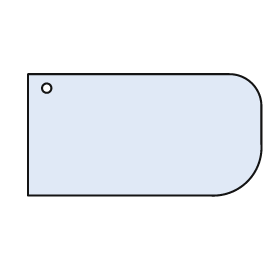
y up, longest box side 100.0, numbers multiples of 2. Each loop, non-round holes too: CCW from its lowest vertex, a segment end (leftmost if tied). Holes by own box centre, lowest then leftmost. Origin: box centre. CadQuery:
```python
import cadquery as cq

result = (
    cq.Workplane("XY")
    .moveTo(-50.0, -26.0)
    .lineTo(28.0, -26.0)
    .threePointArc((44.0, -20.0), (50.0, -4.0))
    .lineTo(50.0, 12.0)
    .threePointArc((46.0, 22.0), (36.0, 26.0))
    .lineTo(-50.0, 26.0)
    .close()
    .moveTo(-42.0, 20.0)
    .circle(2.0)
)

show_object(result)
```